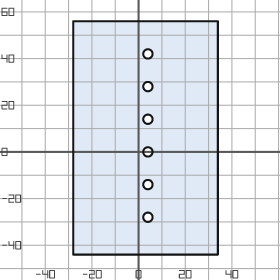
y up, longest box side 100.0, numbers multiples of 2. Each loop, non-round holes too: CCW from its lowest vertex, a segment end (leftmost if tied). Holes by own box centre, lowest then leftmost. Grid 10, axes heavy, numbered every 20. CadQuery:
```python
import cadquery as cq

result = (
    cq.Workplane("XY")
    .moveTo(-28.0, -44.0)
    .lineTo(34.0, -44.0)
    .lineTo(34.0, 56.0)
    .lineTo(-28.0, 56.0)
    .close()
    .moveTo(4.0, -28.0)
    .circle(2.0)
    .moveTo(4.0, -14.0)
    .circle(2.0)
    .moveTo(4.0, 0.0)
    .circle(2.0)
    .moveTo(4.0, 14.0)
    .circle(2.0)
    .moveTo(4.0, 28.0)
    .circle(2.0)
    .moveTo(4.0, 42.0)
    .circle(2.0)
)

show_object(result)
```